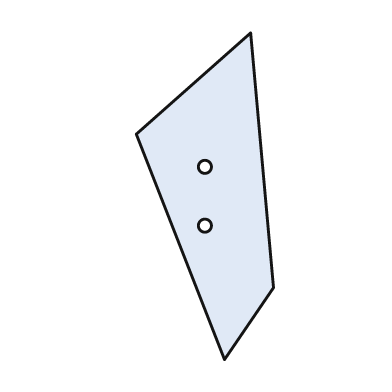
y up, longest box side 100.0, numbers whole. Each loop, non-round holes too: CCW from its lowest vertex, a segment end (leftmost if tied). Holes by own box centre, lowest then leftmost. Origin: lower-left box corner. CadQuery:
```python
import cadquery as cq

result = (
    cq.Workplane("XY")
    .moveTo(27.0, 0.0)
    .lineTo(42.0, 22.0)
    .lineTo(35.0, 100.0)
    .lineTo(0.0, 69.0)
    .close()
    .moveTo(21.0, 41.0)
    .circle(2.0)
    .moveTo(21.0, 59.0)
    .circle(2.0)
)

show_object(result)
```